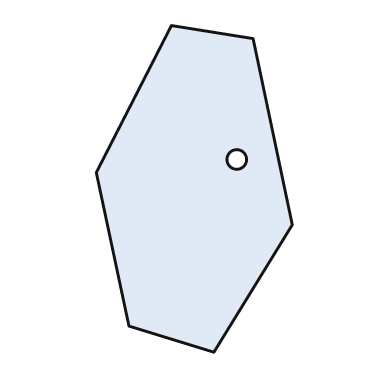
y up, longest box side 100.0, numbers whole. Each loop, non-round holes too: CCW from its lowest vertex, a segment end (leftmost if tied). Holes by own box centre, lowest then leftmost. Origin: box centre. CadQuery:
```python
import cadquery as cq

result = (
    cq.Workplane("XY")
    .moveTo(6.0, -50.0)
    .lineTo(30.0, -11.0)
    .lineTo(18.0, 46.0)
    .lineTo(-7.0, 50.0)
    .lineTo(-30.0, 5.0)
    .lineTo(-20.0, -42.0)
    .close()
    .moveTo(13.0, 9.0)
    .circle(3.0)
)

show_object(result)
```